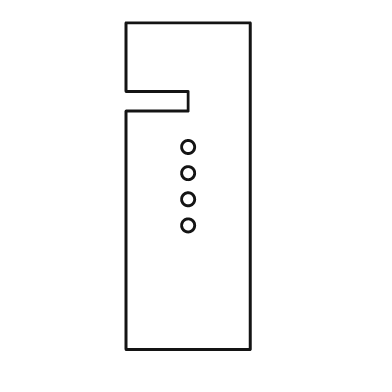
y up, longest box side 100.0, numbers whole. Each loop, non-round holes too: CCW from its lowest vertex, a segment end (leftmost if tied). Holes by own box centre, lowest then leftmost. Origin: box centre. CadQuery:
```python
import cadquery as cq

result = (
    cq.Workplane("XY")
    .moveTo(-19.0, -50.0)
    .lineTo(19.0, -50.0)
    .lineTo(19.0, 50.0)
    .lineTo(-19.0, 50.0)
    .lineTo(-19.0, 29.0)
    .lineTo(0.0, 29.0)
    .lineTo(0.0, 23.0)
    .lineTo(-19.0, 23.0)
    .close()
    .moveTo(0.0, -12.0)
    .circle(2.0)
    .moveTo(0.0, -4.0)
    .circle(2.0)
    .moveTo(0.0, 4.0)
    .circle(2.0)
    .moveTo(0.0, 12.0)
    .circle(2.0)
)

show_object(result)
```